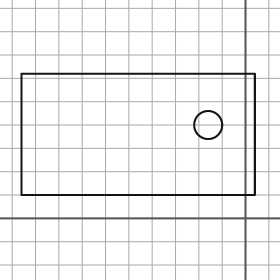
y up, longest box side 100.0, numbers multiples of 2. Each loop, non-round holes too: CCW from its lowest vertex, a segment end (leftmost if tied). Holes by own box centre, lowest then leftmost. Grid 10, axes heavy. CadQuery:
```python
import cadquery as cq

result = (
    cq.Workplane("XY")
    .moveTo(-96.0, 10.0)
    .lineTo(4.0, 10.0)
    .lineTo(4.0, 62.0)
    .lineTo(-96.0, 62.0)
    .close()
    .moveTo(-16.0, 40.0)
    .circle(6.0)
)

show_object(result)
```